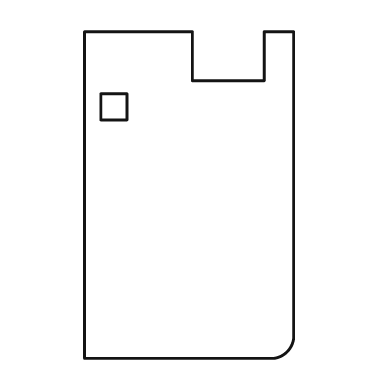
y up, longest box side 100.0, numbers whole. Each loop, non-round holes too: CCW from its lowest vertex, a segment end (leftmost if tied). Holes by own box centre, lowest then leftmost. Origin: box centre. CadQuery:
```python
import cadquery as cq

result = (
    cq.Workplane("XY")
    .moveTo(-32.0, -50.0)
    .lineTo(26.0, -50.0)
    .threePointArc((30.0, -48.0), (32.0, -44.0))
    .lineTo(32.0, 50.0)
    .lineTo(23.0, 50.0)
    .lineTo(23.0, 35.0)
    .lineTo(1.0, 35.0)
    .lineTo(1.0, 50.0)
    .lineTo(-32.0, 50.0)
    .close()
    .moveTo(-27.0, 23.0)
    .lineTo(-19.0, 23.0)
    .lineTo(-19.0, 31.0)
    .lineTo(-27.0, 31.0)
    .close()
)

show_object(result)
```